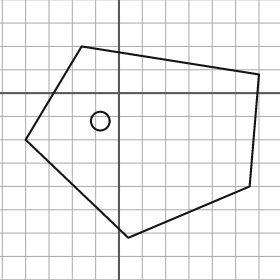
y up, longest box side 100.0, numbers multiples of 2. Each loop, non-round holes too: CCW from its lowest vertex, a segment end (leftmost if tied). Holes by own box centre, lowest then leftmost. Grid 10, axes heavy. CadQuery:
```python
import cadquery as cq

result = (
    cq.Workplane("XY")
    .moveTo(4.0, -62.0)
    .lineTo(56.0, -40.0)
    .lineTo(60.0, 8.0)
    .lineTo(-16.0, 20.0)
    .lineTo(-40.0, -20.0)
    .close()
    .moveTo(-8.0, -12.0)
    .circle(4.0)
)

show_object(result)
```